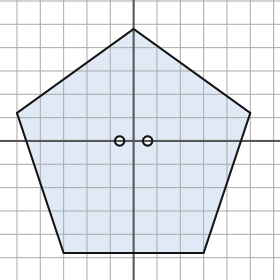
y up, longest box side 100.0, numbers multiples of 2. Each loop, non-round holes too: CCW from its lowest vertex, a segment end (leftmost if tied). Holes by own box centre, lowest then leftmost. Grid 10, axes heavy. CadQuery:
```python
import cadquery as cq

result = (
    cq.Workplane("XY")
    .moveTo(-30.0, -48.0)
    .lineTo(30.0, -48.0)
    .lineTo(50.0, 12.0)
    .lineTo(0.0, 48.0)
    .lineTo(-50.0, 12.0)
    .close()
    .moveTo(-6.0, 0.0)
    .circle(2.0)
    .moveTo(6.0, 0.0)
    .circle(2.0)
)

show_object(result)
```